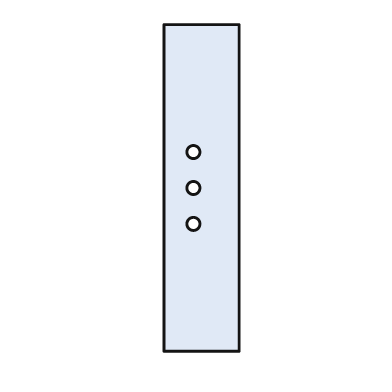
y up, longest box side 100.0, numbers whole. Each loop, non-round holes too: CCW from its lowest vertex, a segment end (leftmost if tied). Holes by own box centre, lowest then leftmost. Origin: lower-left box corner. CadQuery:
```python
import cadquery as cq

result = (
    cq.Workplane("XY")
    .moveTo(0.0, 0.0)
    .lineTo(23.0, 0.0)
    .lineTo(23.0, 100.0)
    .lineTo(0.0, 100.0)
    .close()
    .moveTo(9.0, 39.0)
    .circle(2.0)
    .moveTo(9.0, 50.0)
    .circle(2.0)
    .moveTo(9.0, 61.0)
    .circle(2.0)
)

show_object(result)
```